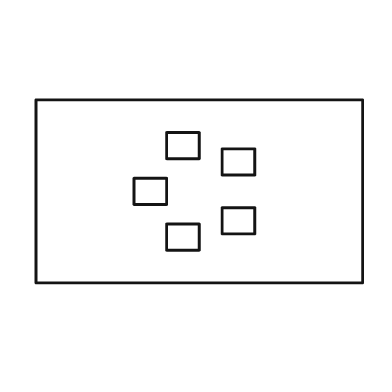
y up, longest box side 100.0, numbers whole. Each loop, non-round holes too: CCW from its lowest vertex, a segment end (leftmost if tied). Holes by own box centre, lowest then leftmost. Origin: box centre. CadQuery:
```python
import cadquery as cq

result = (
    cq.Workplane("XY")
    .moveTo(-50.0, -28.0)
    .lineTo(50.0, -28.0)
    .lineTo(50.0, 28.0)
    .lineTo(-50.0, 28.0)
    .close()
    .moveTo(-10.0, -18.0)
    .lineTo(0.0, -18.0)
    .lineTo(0.0, -10.0)
    .lineTo(-10.0, -10.0)
    .close()
    .moveTo(7.0, -13.0)
    .lineTo(17.0, -13.0)
    .lineTo(17.0, -5.0)
    .lineTo(7.0, -5.0)
    .close()
    .moveTo(-20.0, -4.0)
    .lineTo(-10.0, -4.0)
    .lineTo(-10.0, 4.0)
    .lineTo(-20.0, 4.0)
    .close()
    .moveTo(7.0, 5.0)
    .lineTo(17.0, 5.0)
    .lineTo(17.0, 13.0)
    .lineTo(7.0, 13.0)
    .close()
    .moveTo(-10.0, 10.0)
    .lineTo(0.0, 10.0)
    .lineTo(0.0, 18.0)
    .lineTo(-10.0, 18.0)
    .close()
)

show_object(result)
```